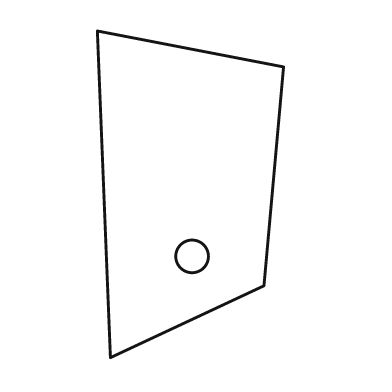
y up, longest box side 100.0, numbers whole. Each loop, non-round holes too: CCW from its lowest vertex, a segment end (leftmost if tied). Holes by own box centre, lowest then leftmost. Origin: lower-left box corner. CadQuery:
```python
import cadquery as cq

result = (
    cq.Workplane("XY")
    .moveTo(4.0, 0.0)
    .lineTo(51.0, 22.0)
    .lineTo(57.0, 89.0)
    .lineTo(0.0, 100.0)
    .close()
    .moveTo(29.0, 31.0)
    .circle(5.0)
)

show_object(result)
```